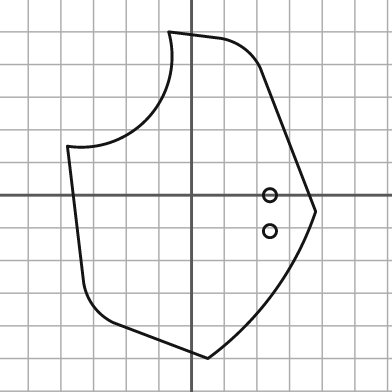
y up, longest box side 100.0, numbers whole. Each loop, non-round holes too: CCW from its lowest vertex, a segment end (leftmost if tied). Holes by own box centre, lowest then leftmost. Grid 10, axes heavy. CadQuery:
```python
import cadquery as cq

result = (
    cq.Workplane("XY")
    .moveTo(5.0, -50.0)
    .threePointArc((25.0, -30.0), (38.0, -5.0))
    .lineTo(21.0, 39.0)
    .threePointArc((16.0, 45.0), (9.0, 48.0))
    .lineTo(-7.0, 50.0)
    .threePointArc((-13.0, 24.0), (-38.0, 15.0))
    .lineTo(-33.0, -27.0)
    .threePointArc((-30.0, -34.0), (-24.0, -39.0))
    .close()
    .moveTo(24.0, -11.0)
    .circle(2.0)
    .moveTo(24.0, 0.0)
    .circle(2.0)
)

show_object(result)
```